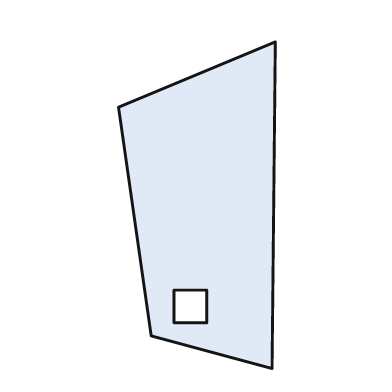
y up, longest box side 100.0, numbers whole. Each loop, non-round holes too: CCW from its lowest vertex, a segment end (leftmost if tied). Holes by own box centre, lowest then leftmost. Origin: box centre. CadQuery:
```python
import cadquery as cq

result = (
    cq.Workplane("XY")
    .moveTo(23.0, -50.0)
    .lineTo(24.0, 50.0)
    .lineTo(-24.0, 30.0)
    .lineTo(-14.0, -40.0)
    .close()
    .moveTo(-7.0, -36.0)
    .lineTo(3.0, -36.0)
    .lineTo(3.0, -26.0)
    .lineTo(-7.0, -26.0)
    .close()
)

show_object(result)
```